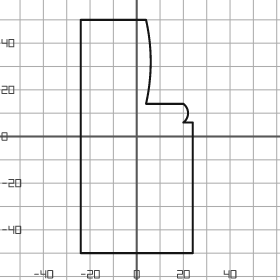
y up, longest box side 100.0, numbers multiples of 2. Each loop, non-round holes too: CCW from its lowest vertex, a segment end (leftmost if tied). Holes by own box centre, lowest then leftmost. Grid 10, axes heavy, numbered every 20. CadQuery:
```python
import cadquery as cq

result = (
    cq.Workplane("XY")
    .moveTo(-24.0, -50.0)
    .lineTo(24.0, -50.0)
    .lineTo(24.0, 6.0)
    .lineTo(20.0, 6.0)
    .threePointArc((22.0, 10.0), (20.0, 14.0))
    .lineTo(4.0, 14.0)
    .threePointArc((6.0, 32.0), (4.0, 50.0))
    .lineTo(-24.0, 50.0)
    .close()
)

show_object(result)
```